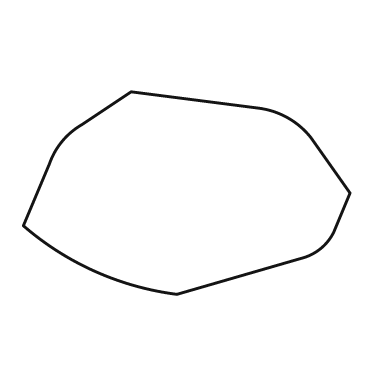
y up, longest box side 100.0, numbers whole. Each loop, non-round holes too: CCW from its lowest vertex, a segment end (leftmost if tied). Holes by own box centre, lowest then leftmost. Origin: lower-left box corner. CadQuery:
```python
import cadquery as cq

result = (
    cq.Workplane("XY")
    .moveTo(47.0, 0.0)
    .lineTo(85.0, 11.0)
    .threePointArc((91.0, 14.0), (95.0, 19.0))
    .lineTo(100.0, 31.0)
    .lineTo(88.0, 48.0)
    .threePointArc((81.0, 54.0), (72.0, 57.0))
    .lineTo(33.0, 62.0)
    .lineTo(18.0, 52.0)
    .threePointArc((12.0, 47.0), (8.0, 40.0))
    .lineTo(0.0, 21.0)
    .threePointArc((22.0, 7.0), (47.0, 0.0))
    .close()
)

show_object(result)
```